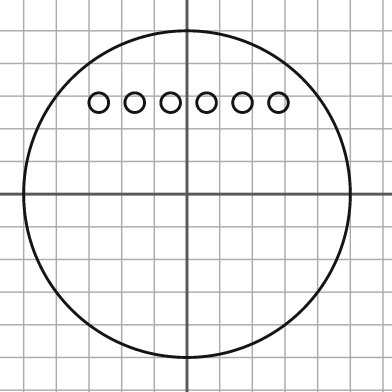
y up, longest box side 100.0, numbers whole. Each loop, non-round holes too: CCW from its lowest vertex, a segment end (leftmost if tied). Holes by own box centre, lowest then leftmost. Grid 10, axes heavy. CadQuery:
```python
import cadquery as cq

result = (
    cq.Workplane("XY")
    .moveTo(0.0, 0.0)
    .circle(50.0)
    .moveTo(-27.0, 28.0)
    .circle(3.0)
    .moveTo(-16.0, 28.0)
    .circle(3.0)
    .moveTo(-5.0, 28.0)
    .circle(3.0)
    .moveTo(6.0, 28.0)
    .circle(3.0)
    .moveTo(17.0, 28.0)
    .circle(3.0)
    .moveTo(28.0, 28.0)
    .circle(3.0)
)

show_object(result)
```